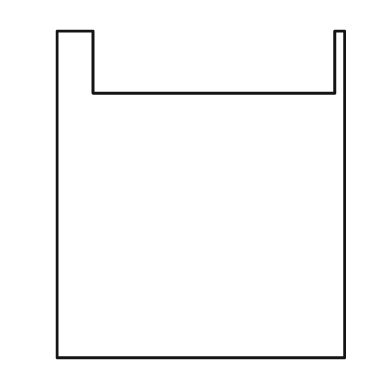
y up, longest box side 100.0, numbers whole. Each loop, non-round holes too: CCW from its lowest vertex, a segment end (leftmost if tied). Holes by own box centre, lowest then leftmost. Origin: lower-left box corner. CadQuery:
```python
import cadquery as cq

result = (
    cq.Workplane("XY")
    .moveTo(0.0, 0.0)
    .lineTo(88.0, 0.0)
    .lineTo(88.0, 100.0)
    .lineTo(85.0, 100.0)
    .lineTo(85.0, 81.0)
    .lineTo(11.0, 81.0)
    .lineTo(11.0, 100.0)
    .lineTo(0.0, 100.0)
    .close()
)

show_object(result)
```